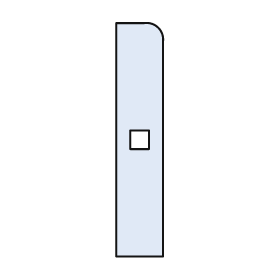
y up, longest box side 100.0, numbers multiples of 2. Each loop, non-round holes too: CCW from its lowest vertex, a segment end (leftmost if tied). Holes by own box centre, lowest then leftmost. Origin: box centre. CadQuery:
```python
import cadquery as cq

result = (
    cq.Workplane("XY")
    .moveTo(-10.0, -50.0)
    .lineTo(10.0, -50.0)
    .lineTo(10.0, 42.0)
    .threePointArc((8.0, 48.0), (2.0, 50.0))
    .lineTo(-10.0, 50.0)
    .close()
    .moveTo(-4.0, -4.0)
    .lineTo(4.0, -4.0)
    .lineTo(4.0, 4.0)
    .lineTo(-4.0, 4.0)
    .close()
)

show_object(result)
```